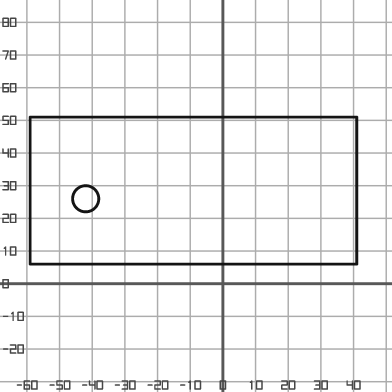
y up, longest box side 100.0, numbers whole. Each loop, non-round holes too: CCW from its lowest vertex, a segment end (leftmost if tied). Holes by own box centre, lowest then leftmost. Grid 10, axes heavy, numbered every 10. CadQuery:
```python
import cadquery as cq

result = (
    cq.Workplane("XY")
    .moveTo(-59.0, 6.0)
    .lineTo(41.0, 6.0)
    .lineTo(41.0, 51.0)
    .lineTo(-59.0, 51.0)
    .close()
    .moveTo(-42.0, 26.0)
    .circle(4.0)
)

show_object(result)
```